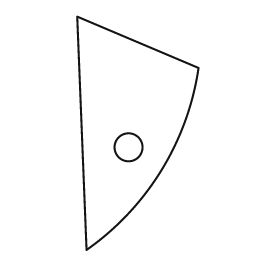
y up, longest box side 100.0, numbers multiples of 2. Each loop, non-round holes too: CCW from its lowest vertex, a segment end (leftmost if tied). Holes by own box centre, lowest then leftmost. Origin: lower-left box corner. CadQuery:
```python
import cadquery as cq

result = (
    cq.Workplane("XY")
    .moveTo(4.0, 0.0)
    .threePointArc((36.0, 34.0), (52.0, 78.0))
    .lineTo(0.0, 100.0)
    .close()
    .moveTo(22.0, 44.0)
    .circle(6.0)
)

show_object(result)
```